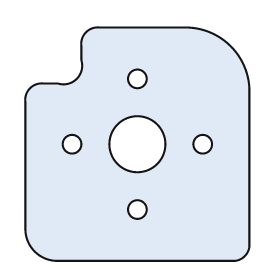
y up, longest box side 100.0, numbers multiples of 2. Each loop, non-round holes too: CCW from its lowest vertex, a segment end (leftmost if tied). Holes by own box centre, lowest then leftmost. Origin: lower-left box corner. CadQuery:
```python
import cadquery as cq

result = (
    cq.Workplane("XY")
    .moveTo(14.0, 0.0)
    .lineTo(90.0, 0.0)
    .threePointArc((94.0, 2.0), (96.0, 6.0))
    .lineTo(96.0, 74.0)
    .threePointArc((88.0, 92.0), (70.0, 100.0))
    .lineTo(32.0, 100.0)
    .threePointArc((26.0, 98.0), (24.0, 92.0))
    .lineTo(24.0, 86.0)
    .threePointArc((22.0, 78.0), (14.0, 76.0))
    .lineTo(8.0, 76.0)
    .threePointArc((2.0, 74.0), (0.0, 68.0))
    .lineTo(0.0, 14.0)
    .threePointArc((4.0, 4.0), (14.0, 0.0))
    .close()
    .moveTo(48.0, 22.0)
    .circle(4.0)
    .moveTo(20.0, 50.0)
    .circle(4.0)
    .moveTo(48.0, 50.0)
    .circle(12.0)
    .moveTo(76.0, 50.0)
    .circle(4.0)
    .moveTo(48.0, 78.0)
    .circle(4.0)
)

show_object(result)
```